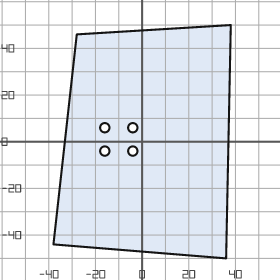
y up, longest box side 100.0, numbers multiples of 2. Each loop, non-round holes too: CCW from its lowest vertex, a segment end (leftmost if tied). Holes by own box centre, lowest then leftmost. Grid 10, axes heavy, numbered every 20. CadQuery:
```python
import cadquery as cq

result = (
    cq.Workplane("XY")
    .moveTo(36.0, -50.0)
    .lineTo(38.0, 50.0)
    .lineTo(-28.0, 46.0)
    .lineTo(-38.0, -44.0)
    .close()
    .moveTo(-16.0, -4.0)
    .circle(2.0)
    .moveTo(-4.0, -4.0)
    .circle(2.0)
    .moveTo(-16.0, 6.0)
    .circle(2.0)
    .moveTo(-4.0, 6.0)
    .circle(2.0)
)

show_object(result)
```